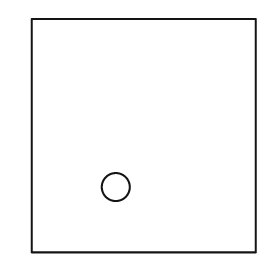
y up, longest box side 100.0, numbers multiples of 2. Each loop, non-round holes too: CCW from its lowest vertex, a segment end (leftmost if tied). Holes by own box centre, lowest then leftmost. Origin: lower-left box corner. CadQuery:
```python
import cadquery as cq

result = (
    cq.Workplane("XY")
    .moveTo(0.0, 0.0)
    .lineTo(96.0, 0.0)
    .lineTo(96.0, 100.0)
    .lineTo(0.0, 100.0)
    .close()
    .moveTo(36.0, 28.0)
    .circle(6.0)
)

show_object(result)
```